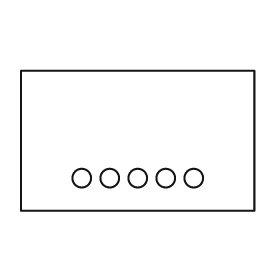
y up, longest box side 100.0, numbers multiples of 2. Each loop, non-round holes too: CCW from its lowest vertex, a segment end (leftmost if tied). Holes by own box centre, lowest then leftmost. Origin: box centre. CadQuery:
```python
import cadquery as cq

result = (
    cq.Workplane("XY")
    .moveTo(-50.0, -30.0)
    .lineTo(50.0, -30.0)
    .lineTo(50.0, 30.0)
    .lineTo(-50.0, 30.0)
    .close()
    .moveTo(-24.0, -16.0)
    .circle(4.0)
    .moveTo(-12.0, -16.0)
    .circle(4.0)
    .moveTo(0.0, -16.0)
    .circle(4.0)
    .moveTo(12.0, -16.0)
    .circle(4.0)
    .moveTo(24.0, -16.0)
    .circle(4.0)
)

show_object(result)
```